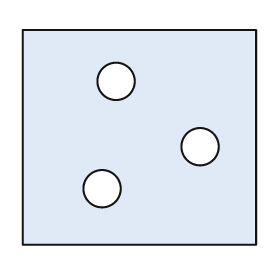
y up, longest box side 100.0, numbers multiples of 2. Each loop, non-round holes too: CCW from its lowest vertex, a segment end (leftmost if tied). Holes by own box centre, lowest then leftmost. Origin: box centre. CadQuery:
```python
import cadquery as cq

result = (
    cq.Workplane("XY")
    .moveTo(-50.0, -46.0)
    .lineTo(50.0, -46.0)
    .lineTo(50.0, 46.0)
    .lineTo(-50.0, 46.0)
    .close()
    .moveTo(-16.0, -22.0)
    .circle(8.0)
    .moveTo(26.0, -4.0)
    .circle(8.0)
    .moveTo(-10.0, 24.0)
    .circle(8.0)
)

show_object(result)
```